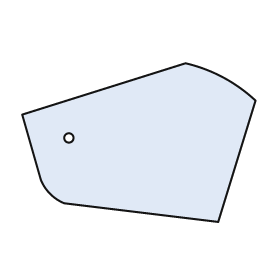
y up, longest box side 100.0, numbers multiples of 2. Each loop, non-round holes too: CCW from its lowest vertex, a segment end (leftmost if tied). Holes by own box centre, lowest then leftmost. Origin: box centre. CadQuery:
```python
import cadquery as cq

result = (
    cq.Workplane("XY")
    .moveTo(34.0, -34.0)
    .lineTo(50.0, 18.0)
    .threePointArc((36.0, 28.0), (20.0, 34.0))
    .lineTo(-50.0, 12.0)
    .lineTo(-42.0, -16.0)
    .threePointArc((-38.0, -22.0), (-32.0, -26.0))
    .close()
    .moveTo(-30.0, 2.0)
    .circle(2.0)
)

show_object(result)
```